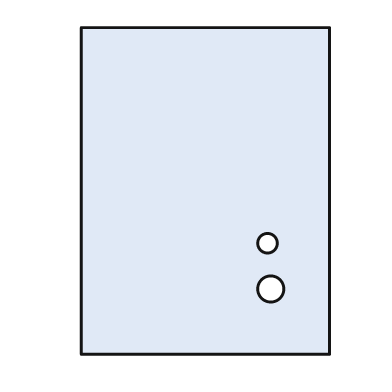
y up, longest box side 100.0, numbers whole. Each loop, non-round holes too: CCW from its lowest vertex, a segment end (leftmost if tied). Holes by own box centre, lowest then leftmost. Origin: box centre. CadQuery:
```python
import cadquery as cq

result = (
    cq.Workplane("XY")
    .moveTo(-38.0, -50.0)
    .lineTo(38.0, -50.0)
    .lineTo(38.0, 50.0)
    .lineTo(-38.0, 50.0)
    .close()
    .moveTo(20.0, -30.0)
    .circle(4.0)
    .moveTo(19.0, -16.0)
    .circle(3.0)
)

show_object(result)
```